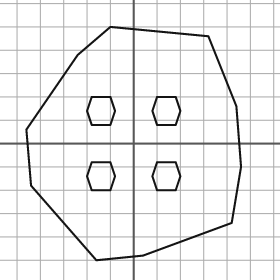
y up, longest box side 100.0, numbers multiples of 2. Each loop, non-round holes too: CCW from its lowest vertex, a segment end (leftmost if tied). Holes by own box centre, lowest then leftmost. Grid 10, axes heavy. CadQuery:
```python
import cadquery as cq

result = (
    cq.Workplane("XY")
    .moveTo(-16.0, -50.0)
    .lineTo(4.0, -48.0)
    .lineTo(42.0, -34.0)
    .lineTo(46.0, -10.0)
    .lineTo(44.0, 16.0)
    .lineTo(32.0, 46.0)
    .lineTo(-10.0, 50.0)
    .lineTo(-24.0, 38.0)
    .lineTo(-46.0, 6.0)
    .lineTo(-44.0, -18.0)
    .close()
    .moveTo(-18.0, -20.0)
    .lineTo(-10.0, -20.0)
    .lineTo(-8.0, -14.0)
    .lineTo(-10.0, -8.0)
    .lineTo(-18.0, -8.0)
    .lineTo(-20.0, -14.0)
    .close()
    .moveTo(10.0, -20.0)
    .lineTo(18.0, -20.0)
    .lineTo(20.0, -14.0)
    .lineTo(18.0, -8.0)
    .lineTo(10.0, -8.0)
    .lineTo(8.0, -14.0)
    .close()
    .moveTo(-18.0, 8.0)
    .lineTo(-10.0, 8.0)
    .lineTo(-8.0, 14.0)
    .lineTo(-10.0, 20.0)
    .lineTo(-18.0, 20.0)
    .lineTo(-20.0, 14.0)
    .close()
    .moveTo(10.0, 8.0)
    .lineTo(18.0, 8.0)
    .lineTo(20.0, 14.0)
    .lineTo(18.0, 20.0)
    .lineTo(10.0, 20.0)
    .lineTo(8.0, 14.0)
    .close()
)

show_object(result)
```